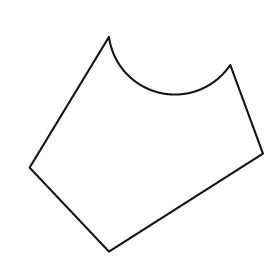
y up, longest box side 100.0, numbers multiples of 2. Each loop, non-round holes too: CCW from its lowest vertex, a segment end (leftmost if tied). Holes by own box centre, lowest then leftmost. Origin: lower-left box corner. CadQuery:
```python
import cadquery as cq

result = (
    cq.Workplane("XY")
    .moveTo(34.0, 0.0)
    .lineTo(100.0, 42.0)
    .lineTo(86.0, 80.0)
    .threePointArc((56.0, 68.0), (34.0, 92.0))
    .lineTo(0.0, 36.0)
    .close()
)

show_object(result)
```